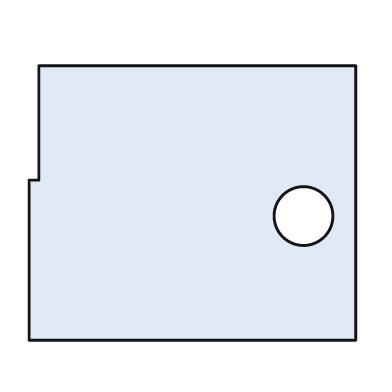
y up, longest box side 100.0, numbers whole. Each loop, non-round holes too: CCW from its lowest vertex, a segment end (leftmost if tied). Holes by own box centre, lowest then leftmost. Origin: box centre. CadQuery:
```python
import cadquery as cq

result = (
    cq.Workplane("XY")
    .moveTo(-50.0, -42.0)
    .lineTo(50.0, -42.0)
    .lineTo(50.0, 42.0)
    .lineTo(-47.0, 42.0)
    .lineTo(-47.0, 7.0)
    .lineTo(-50.0, 7.0)
    .close()
    .moveTo(34.0, -4.0)
    .circle(9.0)
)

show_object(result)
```